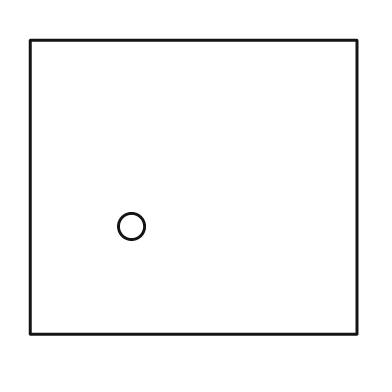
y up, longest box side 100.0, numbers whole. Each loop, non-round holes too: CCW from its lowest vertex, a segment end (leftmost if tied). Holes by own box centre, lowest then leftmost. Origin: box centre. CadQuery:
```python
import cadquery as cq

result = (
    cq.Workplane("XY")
    .moveTo(-50.0, -45.0)
    .lineTo(50.0, -45.0)
    .lineTo(50.0, 45.0)
    .lineTo(-50.0, 45.0)
    .close()
    .moveTo(-19.0, -12.0)
    .circle(4.0)
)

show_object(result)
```